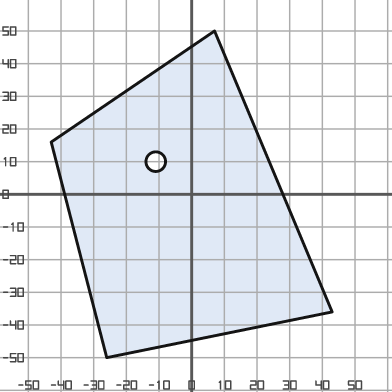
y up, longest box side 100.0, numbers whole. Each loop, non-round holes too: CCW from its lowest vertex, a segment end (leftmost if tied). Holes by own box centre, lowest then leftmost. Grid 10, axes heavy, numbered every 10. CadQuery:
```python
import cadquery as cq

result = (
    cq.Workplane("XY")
    .moveTo(-26.0, -50.0)
    .lineTo(43.0, -36.0)
    .lineTo(7.0, 50.0)
    .lineTo(-43.0, 16.0)
    .close()
    .moveTo(-11.0, 10.0)
    .circle(3.0)
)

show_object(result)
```